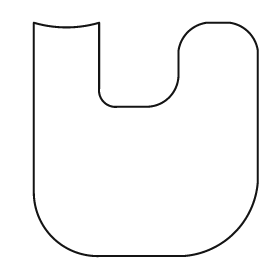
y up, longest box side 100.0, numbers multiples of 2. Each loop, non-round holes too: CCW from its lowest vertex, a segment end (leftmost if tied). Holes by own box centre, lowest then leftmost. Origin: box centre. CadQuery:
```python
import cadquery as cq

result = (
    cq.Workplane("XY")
    .moveTo(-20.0, -50.0)
    .lineTo(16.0, -50.0)
    .threePointArc((38.0, -40.0), (48.0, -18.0))
    .lineTo(48.0, 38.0)
    .threePointArc((44.0, 46.0), (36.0, 50.0))
    .lineTo(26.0, 50.0)
    .threePointArc((18.0, 46.0), (14.0, 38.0))
    .lineTo(14.0, 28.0)
    .threePointArc((10.0, 18.0), (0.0, 14.0))
    .lineTo(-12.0, 14.0)
    .threePointArc((-18.0, 16.0), (-20.0, 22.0))
    .lineTo(-20.0, 50.0)
    .threePointArc((-34.0, 48.0), (-48.0, 50.0))
    .lineTo(-48.0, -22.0)
    .threePointArc((-40.0, -42.0), (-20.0, -50.0))
    .close()
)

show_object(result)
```